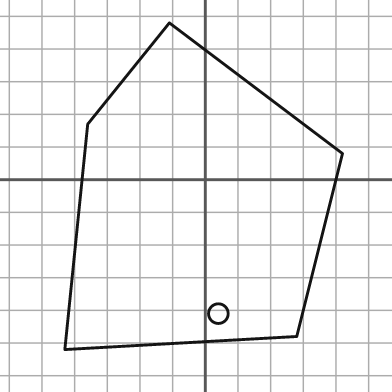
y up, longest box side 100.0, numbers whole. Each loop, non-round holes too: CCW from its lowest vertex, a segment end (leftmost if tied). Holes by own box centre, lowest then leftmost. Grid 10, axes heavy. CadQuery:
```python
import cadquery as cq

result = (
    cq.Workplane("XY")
    .moveTo(-43.0, -52.0)
    .lineTo(28.0, -48.0)
    .lineTo(42.0, 8.0)
    .lineTo(-11.0, 48.0)
    .lineTo(-36.0, 17.0)
    .close()
    .moveTo(4.0, -41.0)
    .circle(3.0)
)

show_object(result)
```